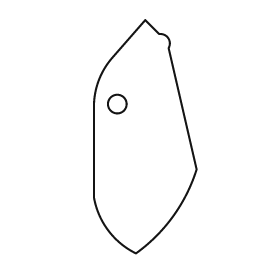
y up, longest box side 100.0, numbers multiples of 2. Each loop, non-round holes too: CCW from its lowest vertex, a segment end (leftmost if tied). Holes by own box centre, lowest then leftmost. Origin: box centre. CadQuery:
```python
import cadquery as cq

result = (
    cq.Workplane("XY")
    .moveTo(-4.0, -50.0)
    .threePointArc((12.0, -34.0), (22.0, -14.0))
    .lineTo(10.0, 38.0)
    .threePointArc((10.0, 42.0), (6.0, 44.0))
    .lineTo(0.0, 50.0)
    .lineTo(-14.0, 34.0)
    .threePointArc((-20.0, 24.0), (-22.0, 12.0))
    .lineTo(-22.0, -26.0)
    .threePointArc((-16.0, -40.0), (-4.0, -50.0))
    .close()
    .moveTo(-12.0, 14.0)
    .circle(4.0)
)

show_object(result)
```